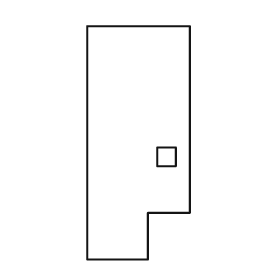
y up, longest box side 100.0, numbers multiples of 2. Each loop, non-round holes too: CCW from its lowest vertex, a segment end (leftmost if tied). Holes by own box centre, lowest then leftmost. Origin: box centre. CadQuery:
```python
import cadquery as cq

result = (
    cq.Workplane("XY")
    .moveTo(-22.0, -50.0)
    .lineTo(4.0, -50.0)
    .lineTo(4.0, -30.0)
    .lineTo(22.0, -30.0)
    .lineTo(22.0, 50.0)
    .lineTo(-22.0, 50.0)
    .close()
    .moveTo(8.0, -10.0)
    .lineTo(16.0, -10.0)
    .lineTo(16.0, -2.0)
    .lineTo(8.0, -2.0)
    .close()
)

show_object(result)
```